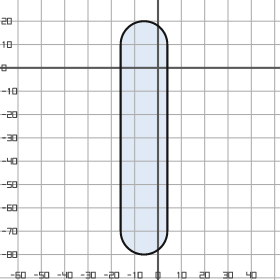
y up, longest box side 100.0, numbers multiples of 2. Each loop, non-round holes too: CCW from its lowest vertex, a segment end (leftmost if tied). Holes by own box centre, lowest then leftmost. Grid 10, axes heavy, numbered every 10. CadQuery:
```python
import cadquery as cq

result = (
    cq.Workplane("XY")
    .moveTo(-16.0, -70.0)
    .threePointArc((-6.0, -80.0), (4.0, -70.0))
    .lineTo(4.0, 10.0)
    .threePointArc((-6.0, 20.0), (-16.0, 10.0))
    .close()
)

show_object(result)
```